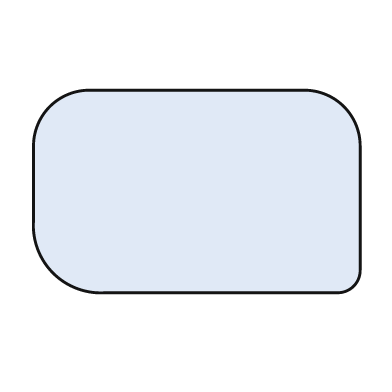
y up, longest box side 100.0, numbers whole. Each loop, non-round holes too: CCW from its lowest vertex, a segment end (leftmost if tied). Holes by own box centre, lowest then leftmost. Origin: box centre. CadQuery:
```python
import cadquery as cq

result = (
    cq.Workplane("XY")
    .moveTo(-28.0, -31.0)
    .lineTo(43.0, -31.0)
    .threePointArc((48.0, -29.0), (50.0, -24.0))
    .lineTo(50.0, 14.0)
    .threePointArc((45.0, 26.0), (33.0, 31.0))
    .lineTo(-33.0, 31.0)
    .threePointArc((-45.0, 26.0), (-50.0, 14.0))
    .lineTo(-50.0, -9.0)
    .threePointArc((-44.0, -25.0), (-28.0, -31.0))
    .close()
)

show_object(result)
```